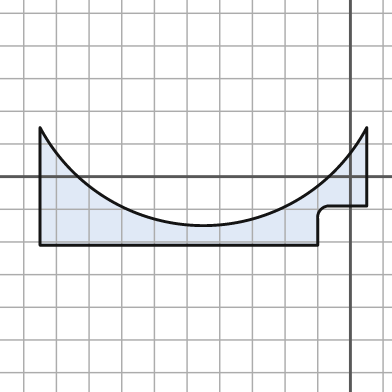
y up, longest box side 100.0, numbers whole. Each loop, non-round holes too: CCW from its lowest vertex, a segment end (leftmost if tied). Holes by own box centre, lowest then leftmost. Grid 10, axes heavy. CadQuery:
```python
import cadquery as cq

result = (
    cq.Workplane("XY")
    .moveTo(-95.0, -21.0)
    .lineTo(-10.0, -21.0)
    .lineTo(-10.0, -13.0)
    .threePointArc((-9.0, -10.0), (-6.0, -9.0))
    .lineTo(5.0, -9.0)
    .lineTo(5.0, 15.0)
    .threePointArc((-45.0, -15.0), (-95.0, 15.0))
    .close()
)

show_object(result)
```